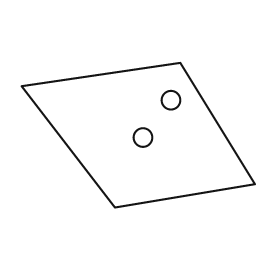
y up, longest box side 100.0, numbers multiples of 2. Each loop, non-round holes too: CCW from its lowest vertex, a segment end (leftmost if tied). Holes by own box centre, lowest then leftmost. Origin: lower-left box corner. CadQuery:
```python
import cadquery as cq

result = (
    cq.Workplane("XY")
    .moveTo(40.0, 0.0)
    .lineTo(100.0, 10.0)
    .lineTo(68.0, 62.0)
    .lineTo(0.0, 52.0)
    .close()
    .moveTo(52.0, 30.0)
    .circle(4.0)
    .moveTo(64.0, 46.0)
    .circle(4.0)
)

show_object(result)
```